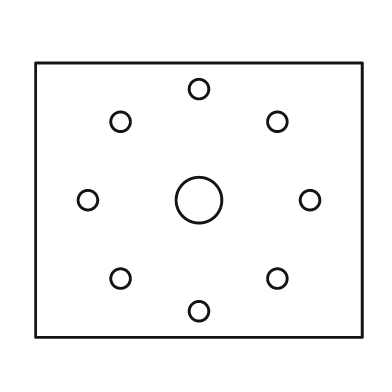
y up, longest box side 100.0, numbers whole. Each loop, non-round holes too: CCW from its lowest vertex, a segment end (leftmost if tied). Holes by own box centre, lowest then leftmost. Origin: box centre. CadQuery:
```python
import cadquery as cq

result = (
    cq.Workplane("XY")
    .moveTo(-50.0, -42.0)
    .lineTo(50.0, -42.0)
    .lineTo(50.0, 42.0)
    .lineTo(-50.0, 42.0)
    .close()
    .moveTo(0.0, -34.0)
    .circle(3.0)
    .moveTo(-24.0, -24.0)
    .circle(3.0)
    .moveTo(24.0, -24.0)
    .circle(3.0)
    .moveTo(-34.0, 0.0)
    .circle(3.0)
    .moveTo(0.0, 0.0)
    .circle(7.0)
    .moveTo(34.0, 0.0)
    .circle(3.0)
    .moveTo(-24.0, 24.0)
    .circle(3.0)
    .moveTo(24.0, 24.0)
    .circle(3.0)
    .moveTo(0.0, 34.0)
    .circle(3.0)
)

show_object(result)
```